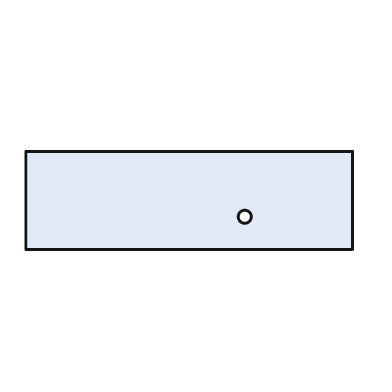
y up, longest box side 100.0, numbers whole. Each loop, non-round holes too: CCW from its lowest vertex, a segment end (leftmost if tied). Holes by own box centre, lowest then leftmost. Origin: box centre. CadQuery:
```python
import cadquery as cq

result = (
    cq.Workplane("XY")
    .moveTo(-50.0, -15.0)
    .lineTo(50.0, -15.0)
    .lineTo(50.0, 15.0)
    .lineTo(-50.0, 15.0)
    .close()
    .moveTo(17.0, -5.0)
    .circle(2.0)
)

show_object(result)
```